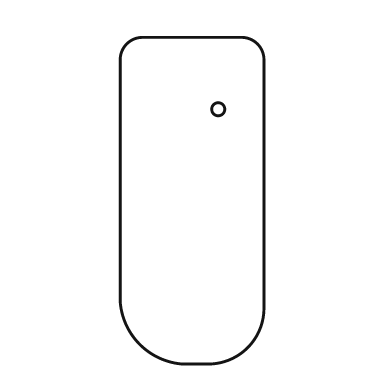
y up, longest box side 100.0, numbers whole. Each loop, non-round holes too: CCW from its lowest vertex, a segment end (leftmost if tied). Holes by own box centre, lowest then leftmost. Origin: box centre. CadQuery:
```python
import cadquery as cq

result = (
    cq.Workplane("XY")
    .moveTo(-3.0, -50.0)
    .lineTo(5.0, -50.0)
    .threePointArc((17.0, -45.0), (22.0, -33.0))
    .lineTo(22.0, 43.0)
    .threePointArc((20.0, 48.0), (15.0, 50.0))
    .lineTo(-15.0, 50.0)
    .threePointArc((-20.0, 48.0), (-22.0, 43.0))
    .lineTo(-22.0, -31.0)
    .threePointArc((-16.0, -44.0), (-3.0, -50.0))
    .close()
    .moveTo(8.0, 28.0)
    .circle(2.0)
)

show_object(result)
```